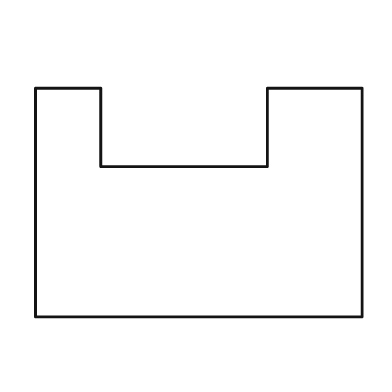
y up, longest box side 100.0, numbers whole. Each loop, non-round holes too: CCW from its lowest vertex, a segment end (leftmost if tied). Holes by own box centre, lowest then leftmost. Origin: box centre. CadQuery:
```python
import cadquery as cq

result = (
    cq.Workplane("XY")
    .moveTo(-50.0, -35.0)
    .lineTo(50.0, -35.0)
    .lineTo(50.0, 35.0)
    .lineTo(21.0, 35.0)
    .lineTo(21.0, 11.0)
    .lineTo(-30.0, 11.0)
    .lineTo(-30.0, 35.0)
    .lineTo(-50.0, 35.0)
    .close()
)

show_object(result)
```